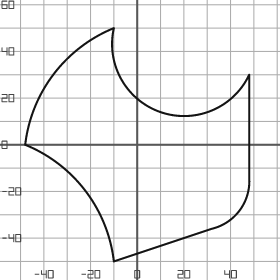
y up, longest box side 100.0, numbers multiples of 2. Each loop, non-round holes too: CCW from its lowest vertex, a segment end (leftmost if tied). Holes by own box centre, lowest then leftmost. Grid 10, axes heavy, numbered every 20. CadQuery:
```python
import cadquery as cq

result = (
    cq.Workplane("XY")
    .moveTo(-10.0, -50.0)
    .lineTo(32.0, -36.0)
    .threePointArc((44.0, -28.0), (48.0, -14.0))
    .lineTo(48.0, 30.0)
    .threePointArc((10.0, 14.0), (-10.0, 50.0))
    .threePointArc((-36.0, 30.0), (-48.0, 0.0))
    .threePointArc((-22.0, -20.0), (-10.0, -50.0))
    .close()
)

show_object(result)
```